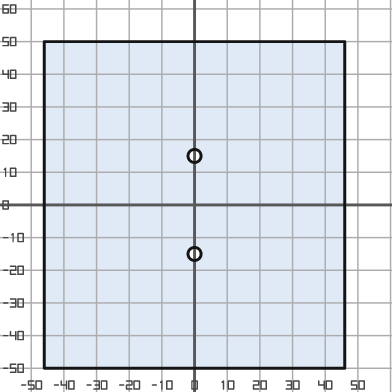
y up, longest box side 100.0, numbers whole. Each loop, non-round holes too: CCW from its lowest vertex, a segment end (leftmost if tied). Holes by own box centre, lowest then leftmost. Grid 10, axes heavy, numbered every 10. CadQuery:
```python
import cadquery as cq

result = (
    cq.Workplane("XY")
    .moveTo(-46.0, -50.0)
    .lineTo(46.0, -50.0)
    .lineTo(46.0, 50.0)
    .lineTo(-46.0, 50.0)
    .close()
    .moveTo(0.0, -15.0)
    .circle(2.0)
    .moveTo(0.0, 15.0)
    .circle(2.0)
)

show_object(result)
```